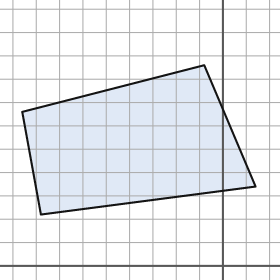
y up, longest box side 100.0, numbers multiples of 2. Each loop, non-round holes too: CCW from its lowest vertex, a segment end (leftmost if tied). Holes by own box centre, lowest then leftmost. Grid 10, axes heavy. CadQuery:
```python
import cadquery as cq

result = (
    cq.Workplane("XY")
    .moveTo(-78.0, 22.0)
    .lineTo(14.0, 34.0)
    .lineTo(-8.0, 86.0)
    .lineTo(-86.0, 66.0)
    .close()
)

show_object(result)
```